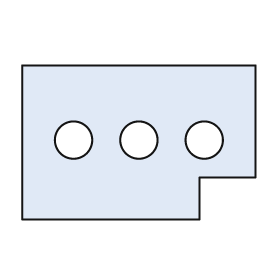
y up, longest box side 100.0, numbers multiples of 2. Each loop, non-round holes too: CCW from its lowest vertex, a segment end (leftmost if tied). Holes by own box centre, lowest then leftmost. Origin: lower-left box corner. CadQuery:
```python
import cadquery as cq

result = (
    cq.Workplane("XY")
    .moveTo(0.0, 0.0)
    .lineTo(76.0, 0.0)
    .lineTo(76.0, 18.0)
    .lineTo(100.0, 18.0)
    .lineTo(100.0, 66.0)
    .lineTo(0.0, 66.0)
    .close()
    .moveTo(22.0, 34.0)
    .circle(8.0)
    .moveTo(50.0, 34.0)
    .circle(8.0)
    .moveTo(78.0, 34.0)
    .circle(8.0)
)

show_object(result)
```